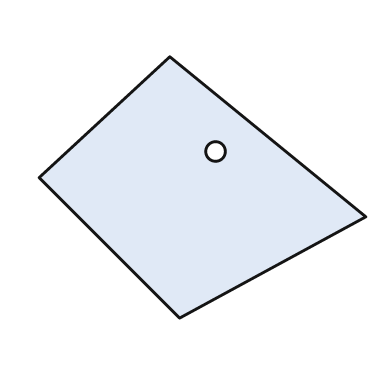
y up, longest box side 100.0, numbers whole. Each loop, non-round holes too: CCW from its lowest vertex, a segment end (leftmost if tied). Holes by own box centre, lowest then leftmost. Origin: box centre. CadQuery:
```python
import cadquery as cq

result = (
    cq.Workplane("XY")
    .moveTo(-7.0, -40.0)
    .lineTo(50.0, -9.0)
    .lineTo(-10.0, 40.0)
    .lineTo(-50.0, 3.0)
    .close()
    .moveTo(4.0, 11.0)
    .circle(3.0)
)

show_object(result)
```